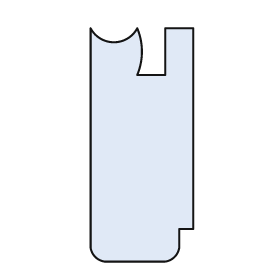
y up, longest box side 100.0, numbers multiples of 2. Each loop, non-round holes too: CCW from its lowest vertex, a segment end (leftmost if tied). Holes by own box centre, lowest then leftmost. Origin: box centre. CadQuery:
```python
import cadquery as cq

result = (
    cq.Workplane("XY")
    .moveTo(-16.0, -50.0)
    .lineTo(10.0, -50.0)
    .threePointArc((14.0, -48.0), (16.0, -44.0))
    .lineTo(16.0, -36.0)
    .lineTo(22.0, -36.0)
    .lineTo(22.0, 50.0)
    .lineTo(10.0, 50.0)
    .lineTo(10.0, 30.0)
    .lineTo(-2.0, 30.0)
    .threePointArc((0.0, 40.0), (-2.0, 50.0))
    .threePointArc((-12.0, 44.0), (-22.0, 50.0))
    .lineTo(-22.0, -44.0)
    .threePointArc((-20.0, -48.0), (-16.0, -50.0))
    .close()
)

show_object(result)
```